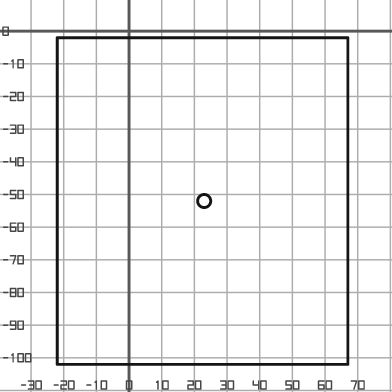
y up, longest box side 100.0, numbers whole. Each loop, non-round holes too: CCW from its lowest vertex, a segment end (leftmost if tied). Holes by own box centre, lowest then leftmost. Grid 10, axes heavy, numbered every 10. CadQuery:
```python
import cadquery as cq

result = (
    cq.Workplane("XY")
    .moveTo(-22.0, -102.0)
    .lineTo(67.0, -102.0)
    .lineTo(67.0, -2.0)
    .lineTo(-22.0, -2.0)
    .close()
    .moveTo(23.0, -52.0)
    .circle(2.0)
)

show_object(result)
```